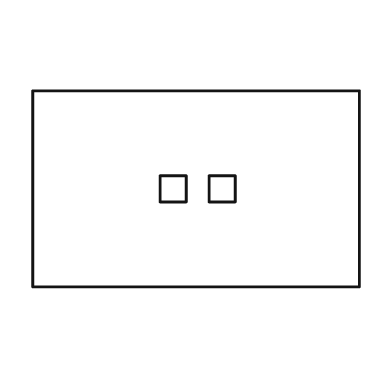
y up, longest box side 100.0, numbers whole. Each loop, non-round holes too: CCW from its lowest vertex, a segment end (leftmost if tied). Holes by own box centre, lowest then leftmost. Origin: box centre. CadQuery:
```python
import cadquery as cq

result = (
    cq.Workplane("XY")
    .moveTo(-50.0, -30.0)
    .lineTo(50.0, -30.0)
    .lineTo(50.0, 30.0)
    .lineTo(-50.0, 30.0)
    .close()
    .moveTo(-11.0, -4.0)
    .lineTo(-3.0, -4.0)
    .lineTo(-3.0, 4.0)
    .lineTo(-11.0, 4.0)
    .close()
    .moveTo(4.0, -4.0)
    .lineTo(12.0, -4.0)
    .lineTo(12.0, 4.0)
    .lineTo(4.0, 4.0)
    .close()
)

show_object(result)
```